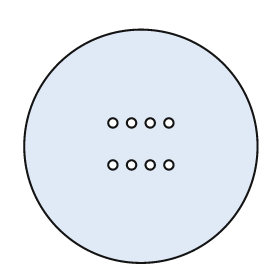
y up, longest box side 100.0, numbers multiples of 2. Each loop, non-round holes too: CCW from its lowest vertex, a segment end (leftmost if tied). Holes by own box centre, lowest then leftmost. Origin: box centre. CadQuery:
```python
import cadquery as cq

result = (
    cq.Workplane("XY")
    .moveTo(0.0, 0.0)
    .circle(50.0)
    .moveTo(-12.0, -8.0)
    .circle(2.0)
    .moveTo(-4.0, -8.0)
    .circle(2.0)
    .moveTo(4.0, -8.0)
    .circle(2.0)
    .moveTo(12.0, -8.0)
    .circle(2.0)
    .moveTo(-12.0, 10.0)
    .circle(2.0)
    .moveTo(-4.0, 10.0)
    .circle(2.0)
    .moveTo(4.0, 10.0)
    .circle(2.0)
    .moveTo(12.0, 10.0)
    .circle(2.0)
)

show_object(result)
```